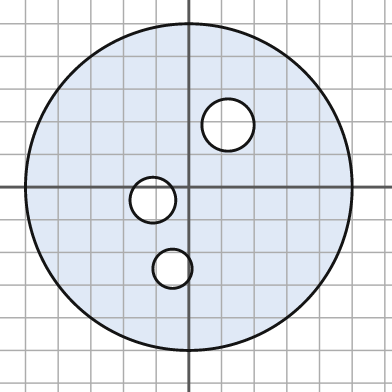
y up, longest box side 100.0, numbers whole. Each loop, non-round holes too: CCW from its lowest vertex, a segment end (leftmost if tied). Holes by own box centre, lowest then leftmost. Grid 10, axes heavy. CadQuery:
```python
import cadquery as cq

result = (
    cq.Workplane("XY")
    .moveTo(0.0, 0.0)
    .circle(50.0)
    .moveTo(-5.0, -25.0)
    .circle(6.0)
    .moveTo(-11.0, -4.0)
    .circle(7.0)
    .moveTo(12.0, 19.0)
    .circle(8.0)
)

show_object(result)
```